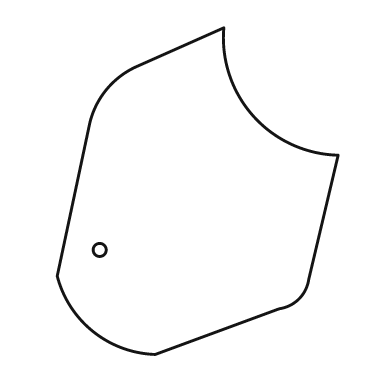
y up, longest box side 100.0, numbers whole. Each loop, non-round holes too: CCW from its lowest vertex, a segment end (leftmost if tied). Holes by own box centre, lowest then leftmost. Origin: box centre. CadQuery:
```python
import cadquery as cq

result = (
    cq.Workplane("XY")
    .moveTo(-13.0, -50.0)
    .lineTo(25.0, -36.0)
    .threePointArc((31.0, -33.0), (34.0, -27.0))
    .lineTo(43.0, 11.0)
    .threePointArc((17.0, 23.0), (8.0, 50.0))
    .lineTo(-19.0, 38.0)
    .threePointArc((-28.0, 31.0), (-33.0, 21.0))
    .lineTo(-43.0, -26.0)
    .threePointArc((-32.0, -43.0), (-13.0, -50.0))
    .close()
    .moveTo(-30.0, -18.0)
    .circle(2.0)
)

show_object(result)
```